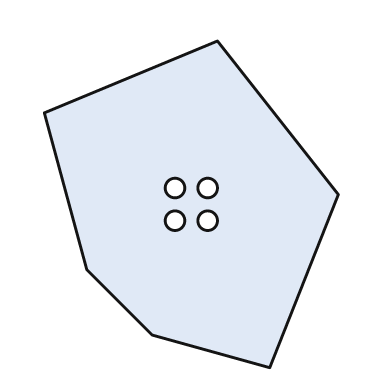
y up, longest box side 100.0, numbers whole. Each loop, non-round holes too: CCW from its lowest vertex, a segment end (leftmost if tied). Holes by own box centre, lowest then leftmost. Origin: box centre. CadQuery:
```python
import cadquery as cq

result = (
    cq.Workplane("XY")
    .moveTo(24.0, -50.0)
    .lineTo(45.0, 3.0)
    .lineTo(8.0, 50.0)
    .lineTo(-45.0, 28.0)
    .lineTo(-32.0, -20.0)
    .lineTo(-12.0, -40.0)
    .close()
    .moveTo(-5.0, -5.0)
    .circle(3.0)
    .moveTo(5.0, -5.0)
    .circle(3.0)
    .moveTo(-5.0, 5.0)
    .circle(3.0)
    .moveTo(5.0, 5.0)
    .circle(3.0)
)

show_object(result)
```